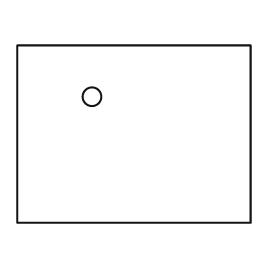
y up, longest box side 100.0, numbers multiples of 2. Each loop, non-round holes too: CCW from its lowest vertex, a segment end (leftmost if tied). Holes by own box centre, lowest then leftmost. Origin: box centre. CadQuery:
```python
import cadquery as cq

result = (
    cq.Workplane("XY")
    .moveTo(-50.0, -38.0)
    .lineTo(50.0, -38.0)
    .lineTo(50.0, 38.0)
    .lineTo(-50.0, 38.0)
    .close()
    .moveTo(-18.0, 16.0)
    .circle(4.0)
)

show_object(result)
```